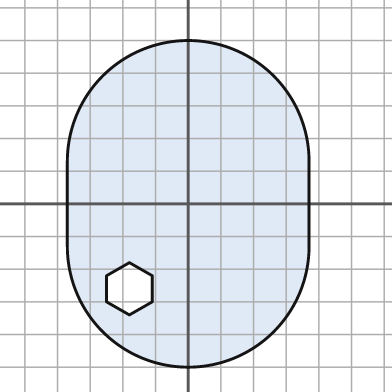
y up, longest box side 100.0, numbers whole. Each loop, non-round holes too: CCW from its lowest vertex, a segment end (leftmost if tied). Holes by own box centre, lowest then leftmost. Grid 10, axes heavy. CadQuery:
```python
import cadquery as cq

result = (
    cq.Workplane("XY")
    .moveTo(-37.0, -13.0)
    .threePointArc((0.0, -50.0), (37.0, -13.0))
    .lineTo(37.0, 13.0)
    .threePointArc((0.0, 50.0), (-37.0, 13.0))
    .close()
    .moveTo(-18.0, -34.0)
    .lineTo(-11.0, -30.0)
    .lineTo(-11.0, -22.0)
    .lineTo(-18.0, -18.0)
    .lineTo(-25.0, -22.0)
    .lineTo(-25.0, -30.0)
    .close()
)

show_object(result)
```